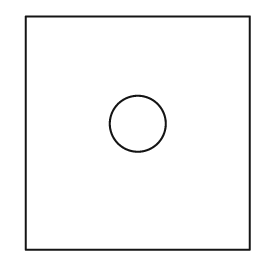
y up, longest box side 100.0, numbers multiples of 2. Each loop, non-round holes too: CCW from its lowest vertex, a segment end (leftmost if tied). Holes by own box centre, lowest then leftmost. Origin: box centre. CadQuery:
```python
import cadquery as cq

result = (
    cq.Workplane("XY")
    .moveTo(-48.0, -50.0)
    .lineTo(48.0, -50.0)
    .lineTo(48.0, 50.0)
    .lineTo(-48.0, 50.0)
    .close()
    .moveTo(0.0, 4.0)
    .circle(12.0)
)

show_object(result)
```